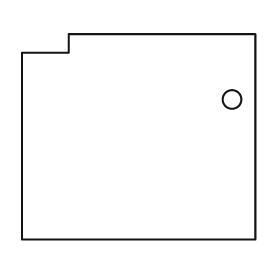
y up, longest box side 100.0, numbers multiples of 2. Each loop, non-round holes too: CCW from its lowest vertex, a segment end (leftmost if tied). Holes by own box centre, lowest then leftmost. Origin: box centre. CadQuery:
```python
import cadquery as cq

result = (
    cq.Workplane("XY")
    .moveTo(-50.0, -44.0)
    .lineTo(50.0, -44.0)
    .lineTo(50.0, 44.0)
    .lineTo(-30.0, 44.0)
    .lineTo(-30.0, 36.0)
    .lineTo(-50.0, 36.0)
    .close()
    .moveTo(40.0, 16.0)
    .circle(4.0)
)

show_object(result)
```